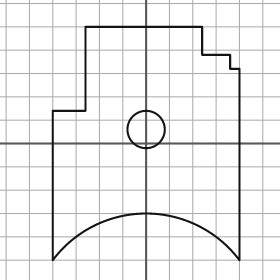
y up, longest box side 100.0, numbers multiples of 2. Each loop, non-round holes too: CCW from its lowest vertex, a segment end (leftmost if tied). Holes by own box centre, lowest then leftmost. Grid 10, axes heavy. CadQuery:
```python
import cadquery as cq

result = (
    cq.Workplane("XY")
    .moveTo(-40.0, -50.0)
    .threePointArc((0.0, -30.0), (40.0, -50.0))
    .lineTo(40.0, 32.0)
    .lineTo(36.0, 32.0)
    .lineTo(36.0, 38.0)
    .lineTo(24.0, 38.0)
    .lineTo(24.0, 50.0)
    .lineTo(-26.0, 50.0)
    .lineTo(-26.0, 14.0)
    .lineTo(-40.0, 14.0)
    .close()
    .moveTo(0.0, 6.0)
    .circle(8.0)
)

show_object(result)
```